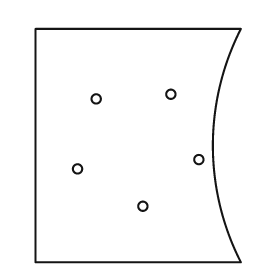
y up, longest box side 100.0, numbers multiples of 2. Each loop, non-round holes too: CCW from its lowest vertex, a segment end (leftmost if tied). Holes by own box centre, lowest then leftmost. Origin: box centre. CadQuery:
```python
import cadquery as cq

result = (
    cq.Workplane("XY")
    .moveTo(-44.0, -50.0)
    .lineTo(44.0, -50.0)
    .threePointArc((32.0, 0.0), (44.0, 50.0))
    .lineTo(-44.0, 50.0)
    .close()
    .moveTo(2.0, -26.0)
    .circle(2.0)
    .moveTo(-26.0, -10.0)
    .circle(2.0)
    .moveTo(26.0, -6.0)
    .circle(2.0)
    .moveTo(-18.0, 20.0)
    .circle(2.0)
    .moveTo(14.0, 22.0)
    .circle(2.0)
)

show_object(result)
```